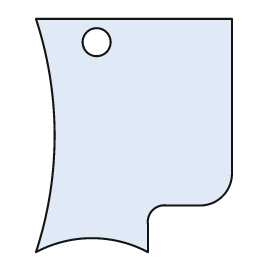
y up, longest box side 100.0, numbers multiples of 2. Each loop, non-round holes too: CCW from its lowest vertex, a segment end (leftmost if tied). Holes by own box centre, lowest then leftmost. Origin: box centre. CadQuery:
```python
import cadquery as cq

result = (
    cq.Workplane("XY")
    .moveTo(-42.0, -50.0)
    .threePointArc((-18.0, -44.0), (6.0, -50.0))
    .lineTo(6.0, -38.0)
    .threePointArc((8.0, -32.0), (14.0, -30.0))
    .lineTo(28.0, -30.0)
    .threePointArc((38.0, -26.0), (42.0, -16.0))
    .lineTo(42.0, 50.0)
    .lineTo(-42.0, 50.0)
    .threePointArc((-34.0, 0.0), (-42.0, -50.0))
    .close()
    .moveTo(-16.0, 40.0)
    .circle(6.0)
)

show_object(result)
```